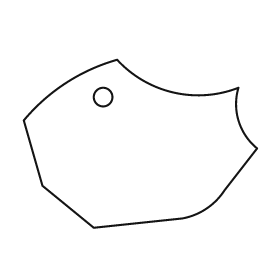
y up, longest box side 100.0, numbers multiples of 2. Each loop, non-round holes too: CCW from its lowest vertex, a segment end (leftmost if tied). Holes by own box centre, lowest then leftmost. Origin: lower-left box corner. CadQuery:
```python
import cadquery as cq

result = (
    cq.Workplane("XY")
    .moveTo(30.0, 0.0)
    .lineTo(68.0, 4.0)
    .threePointArc((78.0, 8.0), (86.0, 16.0))
    .lineTo(100.0, 34.0)
    .threePointArc((92.0, 46.0), (92.0, 60.0))
    .threePointArc((64.0, 58.0), (40.0, 72.0))
    .threePointArc((18.0, 62.0), (0.0, 46.0))
    .lineTo(8.0, 18.0)
    .close()
    .moveTo(34.0, 56.0)
    .circle(4.0)
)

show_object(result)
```